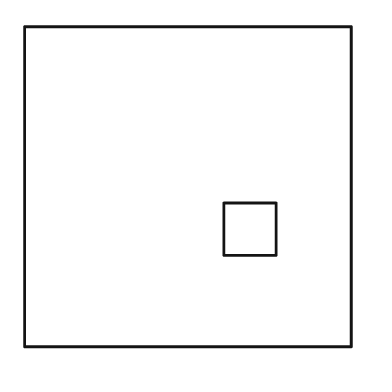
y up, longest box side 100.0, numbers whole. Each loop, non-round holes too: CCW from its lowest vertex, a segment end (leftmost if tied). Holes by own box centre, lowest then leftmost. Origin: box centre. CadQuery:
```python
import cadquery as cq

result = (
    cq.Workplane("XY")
    .moveTo(-50.0, -49.0)
    .lineTo(50.0, -49.0)
    .lineTo(50.0, 49.0)
    .lineTo(-50.0, 49.0)
    .close()
    .moveTo(11.0, -21.0)
    .lineTo(27.0, -21.0)
    .lineTo(27.0, -5.0)
    .lineTo(11.0, -5.0)
    .close()
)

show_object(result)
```